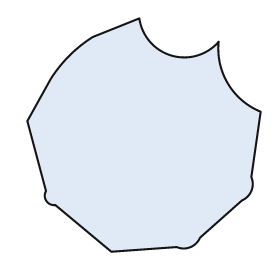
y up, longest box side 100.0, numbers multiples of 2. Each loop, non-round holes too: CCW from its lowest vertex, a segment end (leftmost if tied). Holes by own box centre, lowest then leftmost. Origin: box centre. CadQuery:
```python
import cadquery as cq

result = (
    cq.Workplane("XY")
    .moveTo(-14.0, -50.0)
    .lineTo(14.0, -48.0)
    .threePointArc((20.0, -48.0), (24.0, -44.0))
    .lineTo(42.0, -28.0)
    .threePointArc((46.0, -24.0), (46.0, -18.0))
    .lineTo(50.0, 10.0)
    .threePointArc((36.0, 22.0), (32.0, 40.0))
    .threePointArc((12.0, 34.0), (-2.0, 50.0))
    .lineTo(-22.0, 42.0)
    .threePointArc((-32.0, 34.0), (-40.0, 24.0))
    .lineTo(-50.0, 6.0)
    .lineTo(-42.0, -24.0)
    .threePointArc((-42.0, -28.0), (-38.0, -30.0))
    .close()
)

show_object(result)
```